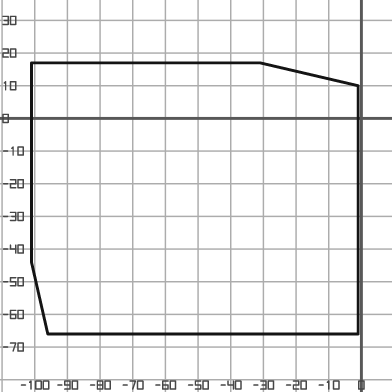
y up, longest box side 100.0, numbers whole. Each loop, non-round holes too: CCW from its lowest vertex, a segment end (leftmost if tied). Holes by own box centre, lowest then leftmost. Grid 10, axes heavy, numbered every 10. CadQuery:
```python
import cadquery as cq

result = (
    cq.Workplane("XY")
    .moveTo(-96.0, -66.0)
    .lineTo(-1.0, -66.0)
    .lineTo(-1.0, 10.0)
    .lineTo(-31.0, 17.0)
    .lineTo(-101.0, 17.0)
    .lineTo(-101.0, -44.0)
    .close()
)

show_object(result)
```